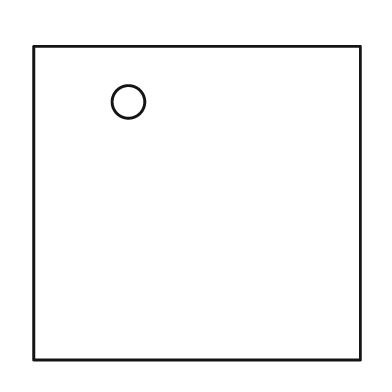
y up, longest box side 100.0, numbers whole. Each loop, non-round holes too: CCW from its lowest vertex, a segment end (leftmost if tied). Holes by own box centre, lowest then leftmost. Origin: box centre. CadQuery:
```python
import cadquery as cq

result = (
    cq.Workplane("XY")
    .moveTo(-50.0, -48.0)
    .lineTo(50.0, -48.0)
    .lineTo(50.0, 48.0)
    .lineTo(-50.0, 48.0)
    .close()
    .moveTo(-21.0, 31.0)
    .circle(5.0)
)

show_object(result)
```